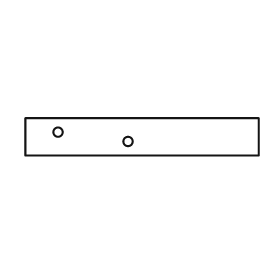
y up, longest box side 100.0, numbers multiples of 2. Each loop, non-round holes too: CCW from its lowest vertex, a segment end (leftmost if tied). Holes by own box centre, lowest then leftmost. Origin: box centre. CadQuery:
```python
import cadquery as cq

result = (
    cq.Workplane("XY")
    .moveTo(-50.0, -8.0)
    .lineTo(50.0, -8.0)
    .lineTo(50.0, 8.0)
    .lineTo(-50.0, 8.0)
    .close()
    .moveTo(-6.0, -2.0)
    .circle(2.0)
    .moveTo(-36.0, 2.0)
    .circle(2.0)
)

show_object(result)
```